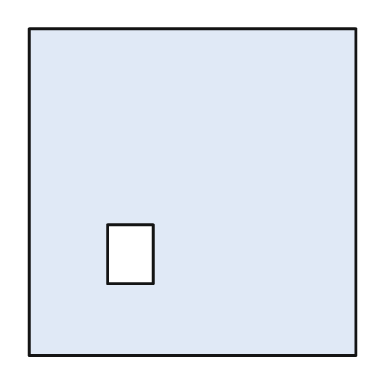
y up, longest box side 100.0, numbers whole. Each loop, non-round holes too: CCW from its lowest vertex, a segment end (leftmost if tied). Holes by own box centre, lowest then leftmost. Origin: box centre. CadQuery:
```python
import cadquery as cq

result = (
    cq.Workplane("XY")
    .moveTo(-50.0, -50.0)
    .lineTo(50.0, -50.0)
    .lineTo(50.0, 50.0)
    .lineTo(-50.0, 50.0)
    .close()
    .moveTo(-26.0, -28.0)
    .lineTo(-12.0, -28.0)
    .lineTo(-12.0, -10.0)
    .lineTo(-26.0, -10.0)
    .close()
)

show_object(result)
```